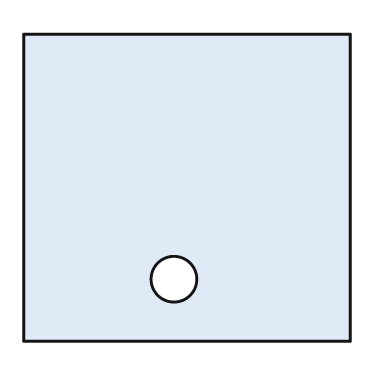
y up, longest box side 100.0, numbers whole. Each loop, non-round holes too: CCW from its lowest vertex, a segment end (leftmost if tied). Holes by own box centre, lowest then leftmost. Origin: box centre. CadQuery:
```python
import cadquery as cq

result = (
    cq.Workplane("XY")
    .moveTo(-50.0, -47.0)
    .lineTo(50.0, -47.0)
    .lineTo(50.0, 47.0)
    .lineTo(-50.0, 47.0)
    .close()
    .moveTo(-4.0, -28.0)
    .circle(7.0)
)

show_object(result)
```